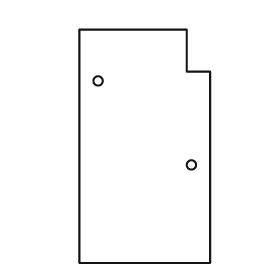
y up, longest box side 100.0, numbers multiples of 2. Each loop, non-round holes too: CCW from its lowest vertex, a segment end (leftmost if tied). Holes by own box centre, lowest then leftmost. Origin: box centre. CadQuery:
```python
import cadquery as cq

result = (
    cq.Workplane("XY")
    .moveTo(-28.0, -50.0)
    .lineTo(28.0, -50.0)
    .lineTo(28.0, 32.0)
    .lineTo(18.0, 32.0)
    .lineTo(18.0, 50.0)
    .lineTo(-28.0, 50.0)
    .close()
    .moveTo(20.0, -8.0)
    .circle(2.0)
    .moveTo(-20.0, 28.0)
    .circle(2.0)
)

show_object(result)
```